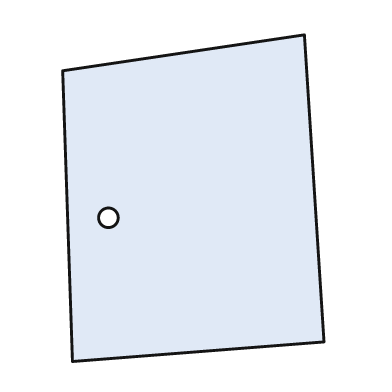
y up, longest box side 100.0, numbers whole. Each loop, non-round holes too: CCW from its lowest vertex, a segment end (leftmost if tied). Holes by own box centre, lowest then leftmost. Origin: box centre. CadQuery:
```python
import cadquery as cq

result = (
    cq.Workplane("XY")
    .moveTo(-37.0, -50.0)
    .lineTo(40.0, -44.0)
    .lineTo(34.0, 50.0)
    .lineTo(-40.0, 39.0)
    .close()
    .moveTo(-26.0, -6.0)
    .circle(3.0)
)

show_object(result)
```